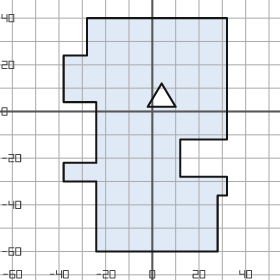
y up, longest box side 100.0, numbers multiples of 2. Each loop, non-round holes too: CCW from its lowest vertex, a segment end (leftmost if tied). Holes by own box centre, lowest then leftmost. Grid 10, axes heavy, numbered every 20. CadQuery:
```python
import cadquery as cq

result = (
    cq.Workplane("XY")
    .moveTo(-24.0, -60.0)
    .lineTo(28.0, -60.0)
    .lineTo(28.0, -36.0)
    .lineTo(32.0, -36.0)
    .lineTo(32.0, -28.0)
    .lineTo(12.0, -28.0)
    .lineTo(12.0, -12.0)
    .lineTo(32.0, -12.0)
    .lineTo(32.0, 40.0)
    .lineTo(-28.0, 40.0)
    .lineTo(-28.0, 24.0)
    .lineTo(-38.0, 24.0)
    .lineTo(-38.0, 4.0)
    .lineTo(-24.0, 4.0)
    .lineTo(-24.0, -22.0)
    .lineTo(-38.0, -22.0)
    .lineTo(-38.0, -30.0)
    .lineTo(-24.0, -30.0)
    .close()
    .moveTo(-2.0, 2.0)
    .lineTo(10.0, 2.0)
    .lineTo(4.0, 12.0)
    .close()
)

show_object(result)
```